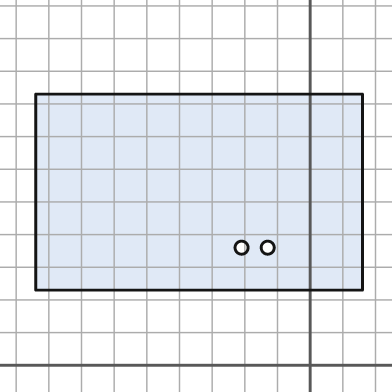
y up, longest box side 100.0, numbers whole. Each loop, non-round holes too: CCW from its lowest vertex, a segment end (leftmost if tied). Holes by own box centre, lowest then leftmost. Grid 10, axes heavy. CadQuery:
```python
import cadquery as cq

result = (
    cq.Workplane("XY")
    .moveTo(-84.0, 23.0)
    .lineTo(16.0, 23.0)
    .lineTo(16.0, 83.0)
    .lineTo(-84.0, 83.0)
    .close()
    .moveTo(-21.0, 36.0)
    .circle(2.0)
    .moveTo(-13.0, 36.0)
    .circle(2.0)
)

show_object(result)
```